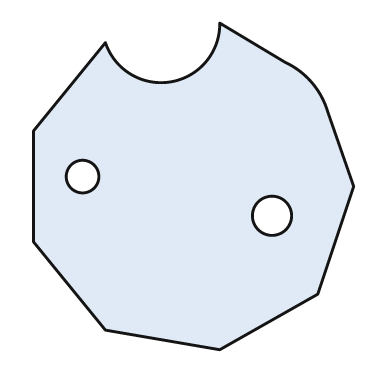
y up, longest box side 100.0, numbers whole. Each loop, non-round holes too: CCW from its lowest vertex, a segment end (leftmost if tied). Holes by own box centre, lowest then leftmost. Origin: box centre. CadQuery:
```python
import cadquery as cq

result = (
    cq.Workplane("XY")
    .moveTo(8.0, -50.0)
    .lineTo(38.0, -33.0)
    .lineTo(49.0, 0.0)
    .lineTo(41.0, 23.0)
    .threePointArc((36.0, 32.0), (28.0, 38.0))
    .lineTo(8.0, 50.0)
    .threePointArc((-7.0, 32.0), (-27.0, 44.0))
    .lineTo(-49.0, 17.0)
    .lineTo(-49.0, -17.0)
    .lineTo(-27.0, -44.0)
    .close()
    .moveTo(24.0, -9.0)
    .circle(6.0)
    .moveTo(-34.0, 3.0)
    .circle(5.0)
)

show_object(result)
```